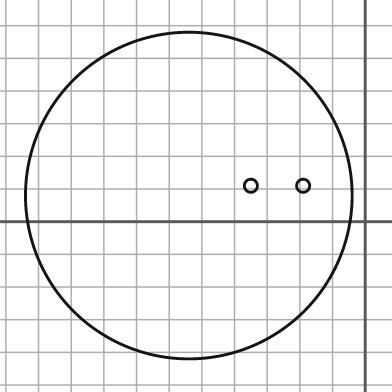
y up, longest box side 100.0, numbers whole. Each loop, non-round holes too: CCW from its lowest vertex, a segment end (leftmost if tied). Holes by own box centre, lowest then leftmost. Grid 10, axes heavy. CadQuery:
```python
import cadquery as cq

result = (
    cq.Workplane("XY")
    .moveTo(-54.0, 8.0)
    .circle(50.0)
    .moveTo(-35.0, 11.0)
    .circle(2.0)
    .moveTo(-19.0, 11.0)
    .circle(2.0)
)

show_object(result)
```